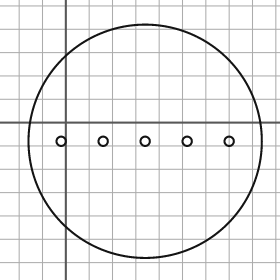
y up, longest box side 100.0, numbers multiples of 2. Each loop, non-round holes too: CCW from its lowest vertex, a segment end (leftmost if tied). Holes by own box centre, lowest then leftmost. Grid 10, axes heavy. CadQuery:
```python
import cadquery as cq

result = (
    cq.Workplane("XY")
    .moveTo(34.0, -8.0)
    .circle(50.0)
    .moveTo(-2.0, -8.0)
    .circle(2.0)
    .moveTo(16.0, -8.0)
    .circle(2.0)
    .moveTo(34.0, -8.0)
    .circle(2.0)
    .moveTo(52.0, -8.0)
    .circle(2.0)
    .moveTo(70.0, -8.0)
    .circle(2.0)
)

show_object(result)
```